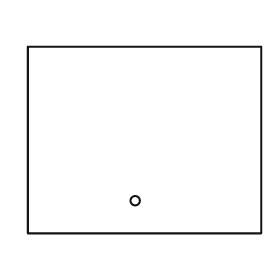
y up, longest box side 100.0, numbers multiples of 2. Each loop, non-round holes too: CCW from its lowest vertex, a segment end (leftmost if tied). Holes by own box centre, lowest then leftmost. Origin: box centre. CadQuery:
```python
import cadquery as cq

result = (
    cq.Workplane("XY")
    .moveTo(-50.0, -40.0)
    .lineTo(50.0, -40.0)
    .lineTo(50.0, 40.0)
    .lineTo(-50.0, 40.0)
    .close()
    .moveTo(-4.0, -26.0)
    .circle(2.0)
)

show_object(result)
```